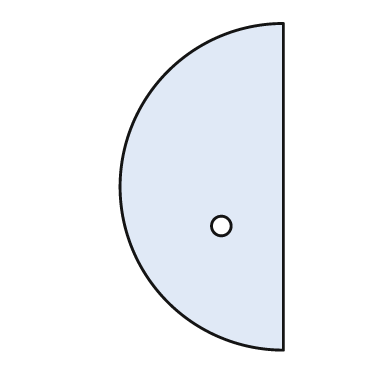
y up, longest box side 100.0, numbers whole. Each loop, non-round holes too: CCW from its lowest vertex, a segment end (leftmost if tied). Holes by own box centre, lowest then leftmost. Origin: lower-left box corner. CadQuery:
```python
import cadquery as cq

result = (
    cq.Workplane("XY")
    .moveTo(50.0, 0.0)
    .lineTo(50.0, 100.0)
    .threePointArc((0.0, 50.0), (50.0, 0.0))
    .close()
    .moveTo(31.0, 38.0)
    .circle(3.0)
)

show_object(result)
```